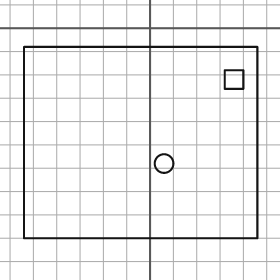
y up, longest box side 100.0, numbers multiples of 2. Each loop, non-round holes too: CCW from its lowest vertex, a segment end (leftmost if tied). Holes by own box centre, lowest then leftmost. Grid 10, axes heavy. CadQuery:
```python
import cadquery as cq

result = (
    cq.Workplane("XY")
    .moveTo(-54.0, -90.0)
    .lineTo(46.0, -90.0)
    .lineTo(46.0, -8.0)
    .lineTo(-54.0, -8.0)
    .close()
    .moveTo(6.0, -58.0)
    .circle(4.0)
    .moveTo(32.0, -26.0)
    .lineTo(40.0, -26.0)
    .lineTo(40.0, -18.0)
    .lineTo(32.0, -18.0)
    .close()
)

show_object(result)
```